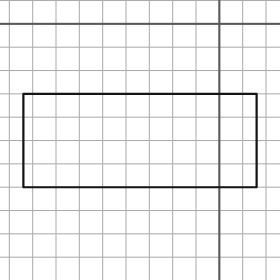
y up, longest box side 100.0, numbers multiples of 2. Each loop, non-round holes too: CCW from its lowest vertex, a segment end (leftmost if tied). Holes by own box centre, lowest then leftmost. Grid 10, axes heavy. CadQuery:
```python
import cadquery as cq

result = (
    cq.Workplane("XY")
    .moveTo(-84.0, -70.0)
    .lineTo(16.0, -70.0)
    .lineTo(16.0, -30.0)
    .lineTo(-84.0, -30.0)
    .close()
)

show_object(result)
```